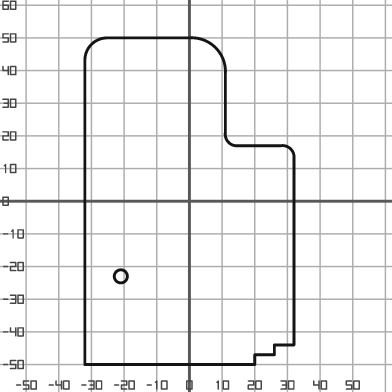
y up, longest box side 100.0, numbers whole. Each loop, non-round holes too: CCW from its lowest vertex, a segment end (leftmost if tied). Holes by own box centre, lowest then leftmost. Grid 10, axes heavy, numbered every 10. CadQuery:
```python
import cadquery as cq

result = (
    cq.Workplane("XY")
    .moveTo(-32.0, -50.0)
    .lineTo(20.0, -50.0)
    .lineTo(20.0, -47.0)
    .lineTo(26.0, -47.0)
    .lineTo(26.0, -44.0)
    .lineTo(32.0, -44.0)
    .lineTo(32.0, 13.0)
    .threePointArc((31.0, 16.0), (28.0, 17.0))
    .lineTo(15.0, 17.0)
    .threePointArc((12.0, 18.0), (11.0, 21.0))
    .lineTo(11.0, 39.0)
    .threePointArc((8.0, 47.0), (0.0, 50.0))
    .lineTo(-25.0, 50.0)
    .threePointArc((-30.0, 48.0), (-32.0, 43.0))
    .close()
    .moveTo(-21.0, -23.0)
    .circle(2.0)
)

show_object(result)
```